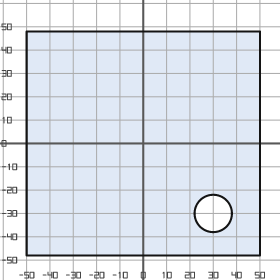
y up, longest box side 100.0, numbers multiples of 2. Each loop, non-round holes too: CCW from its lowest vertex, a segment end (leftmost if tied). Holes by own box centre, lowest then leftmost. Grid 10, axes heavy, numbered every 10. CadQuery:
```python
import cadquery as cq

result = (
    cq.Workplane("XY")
    .moveTo(-50.0, -48.0)
    .lineTo(50.0, -48.0)
    .lineTo(50.0, 48.0)
    .lineTo(-50.0, 48.0)
    .close()
    .moveTo(30.0, -30.0)
    .circle(8.0)
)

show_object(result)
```